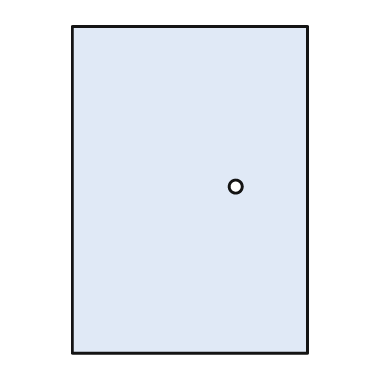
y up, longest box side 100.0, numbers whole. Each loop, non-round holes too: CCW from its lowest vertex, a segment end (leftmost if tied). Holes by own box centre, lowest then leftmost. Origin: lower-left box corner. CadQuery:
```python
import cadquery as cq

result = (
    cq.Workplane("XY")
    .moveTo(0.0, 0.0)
    .lineTo(72.0, 0.0)
    .lineTo(72.0, 100.0)
    .lineTo(0.0, 100.0)
    .close()
    .moveTo(50.0, 51.0)
    .circle(2.0)
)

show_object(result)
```